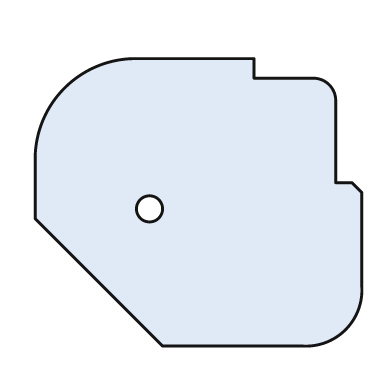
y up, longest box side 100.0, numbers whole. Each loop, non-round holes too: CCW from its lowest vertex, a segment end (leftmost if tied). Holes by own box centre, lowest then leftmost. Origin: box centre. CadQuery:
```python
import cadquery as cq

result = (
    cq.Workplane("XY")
    .moveTo(-11.0, -44.0)
    .lineTo(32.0, -44.0)
    .threePointArc((45.0, -39.0), (50.0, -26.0))
    .lineTo(50.0, 3.0)
    .lineTo(47.0, 6.0)
    .lineTo(42.0, 6.0)
    .lineTo(42.0, 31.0)
    .threePointArc((40.0, 36.0), (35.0, 38.0))
    .lineTo(17.0, 38.0)
    .lineTo(17.0, 44.0)
    .lineTo(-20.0, 44.0)
    .threePointArc((-41.0, 35.0), (-50.0, 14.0))
    .lineTo(-50.0, -5.0)
    .close()
    .moveTo(-15.0, -2.0)
    .circle(4.0)
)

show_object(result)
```